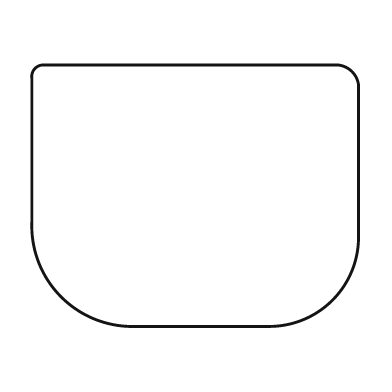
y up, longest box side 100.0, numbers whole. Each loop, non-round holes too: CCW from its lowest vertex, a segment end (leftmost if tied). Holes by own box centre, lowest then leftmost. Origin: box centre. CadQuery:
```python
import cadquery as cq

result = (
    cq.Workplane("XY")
    .moveTo(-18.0, -40.0)
    .lineTo(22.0, -40.0)
    .threePointArc((42.0, -32.0), (50.0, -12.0))
    .lineTo(50.0, 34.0)
    .threePointArc((48.0, 38.0), (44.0, 40.0))
    .lineTo(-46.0, 40.0)
    .threePointArc((-49.0, 39.0), (-50.0, 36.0))
    .lineTo(-50.0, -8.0)
    .threePointArc((-41.0, -31.0), (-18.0, -40.0))
    .close()
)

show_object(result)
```